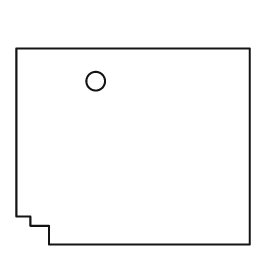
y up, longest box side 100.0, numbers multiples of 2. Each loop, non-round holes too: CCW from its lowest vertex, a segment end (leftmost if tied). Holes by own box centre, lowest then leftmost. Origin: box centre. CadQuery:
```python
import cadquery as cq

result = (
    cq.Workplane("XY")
    .moveTo(-36.0, -42.0)
    .lineTo(50.0, -42.0)
    .lineTo(50.0, 42.0)
    .lineTo(-50.0, 42.0)
    .lineTo(-50.0, -30.0)
    .lineTo(-44.0, -30.0)
    .lineTo(-44.0, -34.0)
    .lineTo(-36.0, -34.0)
    .close()
    .moveTo(-16.0, 28.0)
    .circle(4.0)
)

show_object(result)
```